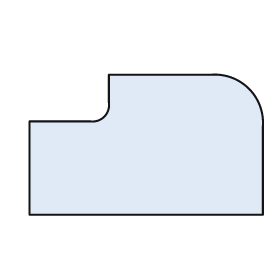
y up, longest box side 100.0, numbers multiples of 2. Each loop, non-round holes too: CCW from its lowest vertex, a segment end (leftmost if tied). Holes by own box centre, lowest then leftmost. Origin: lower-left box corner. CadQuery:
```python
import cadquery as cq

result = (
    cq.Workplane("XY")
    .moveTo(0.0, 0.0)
    .lineTo(100.0, 0.0)
    .lineTo(100.0, 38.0)
    .threePointArc((94.0, 54.0), (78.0, 60.0))
    .lineTo(34.0, 60.0)
    .lineTo(34.0, 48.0)
    .threePointArc((32.0, 42.0), (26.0, 40.0))
    .lineTo(0.0, 40.0)
    .close()
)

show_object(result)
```